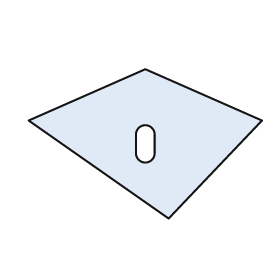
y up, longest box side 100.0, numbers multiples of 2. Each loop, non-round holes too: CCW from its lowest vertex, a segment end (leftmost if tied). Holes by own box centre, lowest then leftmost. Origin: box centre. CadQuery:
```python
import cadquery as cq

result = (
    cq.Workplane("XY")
    .moveTo(10.0, -32.0)
    .lineTo(50.0, 10.0)
    .lineTo(0.0, 32.0)
    .lineTo(-50.0, 10.0)
    .close()
    .moveTo(-4.0, -4.0)
    .threePointArc((0.0, -8.0), (4.0, -4.0))
    .lineTo(4.0, 4.0)
    .threePointArc((0.0, 8.0), (-4.0, 4.0))
    .close()
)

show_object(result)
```